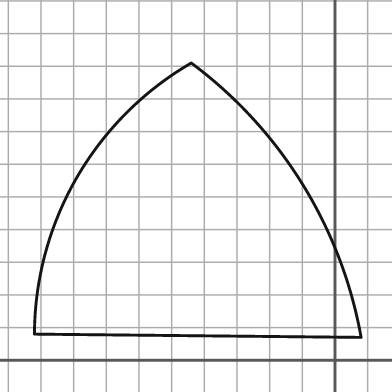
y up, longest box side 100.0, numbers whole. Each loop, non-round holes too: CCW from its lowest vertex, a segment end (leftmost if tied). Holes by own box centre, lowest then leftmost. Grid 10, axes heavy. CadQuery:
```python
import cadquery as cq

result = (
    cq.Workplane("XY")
    .moveTo(8.0, 7.0)
    .threePointArc((-10.0, 54.0), (-44.0, 91.0))
    .threePointArc((-79.0, 56.0), (-92.0, 8.0))
    .close()
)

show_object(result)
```